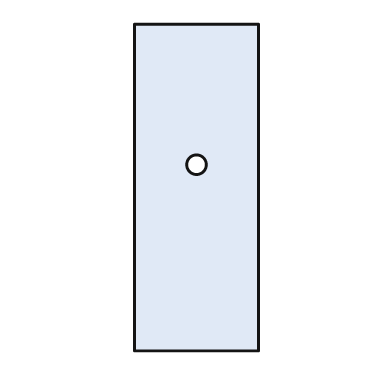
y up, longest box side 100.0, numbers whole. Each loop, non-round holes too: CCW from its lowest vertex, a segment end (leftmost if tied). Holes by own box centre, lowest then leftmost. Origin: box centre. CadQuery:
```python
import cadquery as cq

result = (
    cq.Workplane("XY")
    .moveTo(-19.0, -50.0)
    .lineTo(19.0, -50.0)
    .lineTo(19.0, 50.0)
    .lineTo(-19.0, 50.0)
    .close()
    .moveTo(0.0, 7.0)
    .circle(3.0)
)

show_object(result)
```